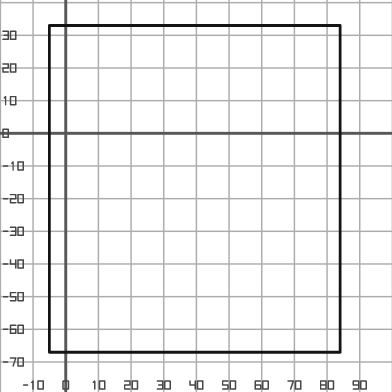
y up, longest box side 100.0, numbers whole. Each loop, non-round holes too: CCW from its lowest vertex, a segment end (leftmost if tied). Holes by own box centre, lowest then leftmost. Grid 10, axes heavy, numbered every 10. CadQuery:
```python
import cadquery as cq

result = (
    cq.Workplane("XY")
    .moveTo(-5.0, -67.0)
    .lineTo(84.0, -67.0)
    .lineTo(84.0, 33.0)
    .lineTo(-5.0, 33.0)
    .close()
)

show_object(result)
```